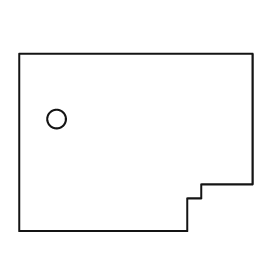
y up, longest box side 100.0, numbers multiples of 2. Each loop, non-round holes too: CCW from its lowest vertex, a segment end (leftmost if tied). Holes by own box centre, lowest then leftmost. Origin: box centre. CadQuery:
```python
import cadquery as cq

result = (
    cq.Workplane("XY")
    .moveTo(-50.0, -38.0)
    .lineTo(22.0, -38.0)
    .lineTo(22.0, -24.0)
    .lineTo(28.0, -24.0)
    .lineTo(28.0, -18.0)
    .lineTo(50.0, -18.0)
    .lineTo(50.0, 38.0)
    .lineTo(-50.0, 38.0)
    .close()
    .moveTo(-34.0, 10.0)
    .circle(4.0)
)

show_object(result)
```